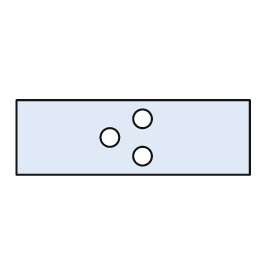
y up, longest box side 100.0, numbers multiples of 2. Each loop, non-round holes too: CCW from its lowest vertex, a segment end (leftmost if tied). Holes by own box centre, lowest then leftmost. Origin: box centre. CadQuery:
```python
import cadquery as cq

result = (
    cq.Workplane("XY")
    .moveTo(-50.0, -16.0)
    .lineTo(50.0, -16.0)
    .lineTo(50.0, 16.0)
    .lineTo(-50.0, 16.0)
    .close()
    .moveTo(4.0, -8.0)
    .circle(4.0)
    .moveTo(-10.0, 0.0)
    .circle(4.0)
    .moveTo(4.0, 8.0)
    .circle(4.0)
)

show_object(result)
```